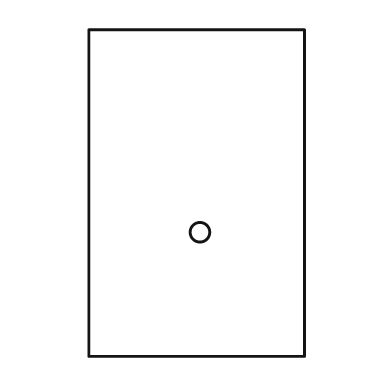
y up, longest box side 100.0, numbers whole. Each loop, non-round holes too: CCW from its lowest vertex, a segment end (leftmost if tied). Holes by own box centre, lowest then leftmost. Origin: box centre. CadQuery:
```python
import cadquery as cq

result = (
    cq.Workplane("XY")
    .moveTo(-33.0, -50.0)
    .lineTo(33.0, -50.0)
    .lineTo(33.0, 50.0)
    .lineTo(-33.0, 50.0)
    .close()
    .moveTo(1.0, -12.0)
    .circle(3.0)
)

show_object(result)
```